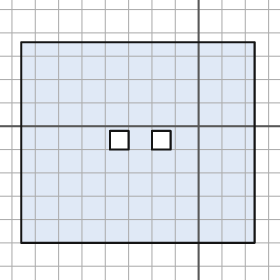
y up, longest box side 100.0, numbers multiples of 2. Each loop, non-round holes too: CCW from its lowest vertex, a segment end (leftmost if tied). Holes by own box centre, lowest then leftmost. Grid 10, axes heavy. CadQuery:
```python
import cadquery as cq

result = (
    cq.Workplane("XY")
    .moveTo(-76.0, -50.0)
    .lineTo(24.0, -50.0)
    .lineTo(24.0, 36.0)
    .lineTo(-76.0, 36.0)
    .close()
    .moveTo(-38.0, -10.0)
    .lineTo(-30.0, -10.0)
    .lineTo(-30.0, -2.0)
    .lineTo(-38.0, -2.0)
    .close()
    .moveTo(-20.0, -10.0)
    .lineTo(-12.0, -10.0)
    .lineTo(-12.0, -2.0)
    .lineTo(-20.0, -2.0)
    .close()
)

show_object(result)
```